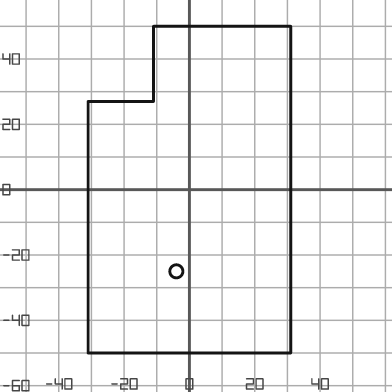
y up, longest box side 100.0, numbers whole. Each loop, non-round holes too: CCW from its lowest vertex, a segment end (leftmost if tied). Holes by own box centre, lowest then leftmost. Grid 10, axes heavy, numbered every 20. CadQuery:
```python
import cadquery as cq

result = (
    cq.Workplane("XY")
    .moveTo(-31.0, -50.0)
    .lineTo(31.0, -50.0)
    .lineTo(31.0, 50.0)
    .lineTo(-11.0, 50.0)
    .lineTo(-11.0, 27.0)
    .lineTo(-31.0, 27.0)
    .close()
    .moveTo(-4.0, -25.0)
    .circle(2.0)
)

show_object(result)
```